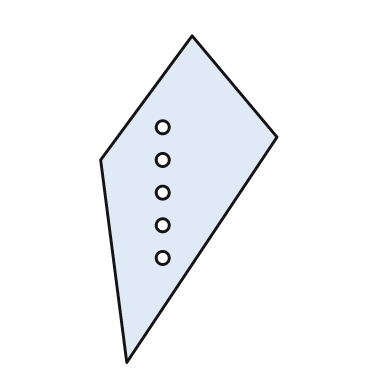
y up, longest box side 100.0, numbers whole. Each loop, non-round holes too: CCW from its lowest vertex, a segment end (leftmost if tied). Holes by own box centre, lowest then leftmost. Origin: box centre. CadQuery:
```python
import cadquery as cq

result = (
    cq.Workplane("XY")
    .moveTo(-19.0, -50.0)
    .lineTo(27.0, 19.0)
    .lineTo(1.0, 50.0)
    .lineTo(-27.0, 12.0)
    .close()
    .moveTo(-8.0, -18.0)
    .circle(2.0)
    .moveTo(-8.0, -8.0)
    .circle(2.0)
    .moveTo(-8.0, 2.0)
    .circle(2.0)
    .moveTo(-8.0, 12.0)
    .circle(2.0)
    .moveTo(-8.0, 22.0)
    .circle(2.0)
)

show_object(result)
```